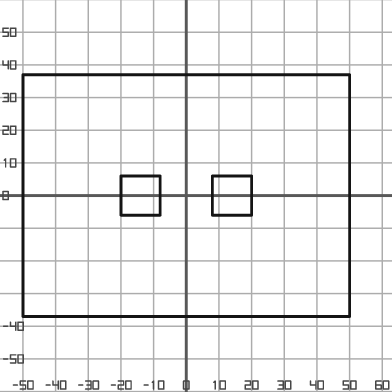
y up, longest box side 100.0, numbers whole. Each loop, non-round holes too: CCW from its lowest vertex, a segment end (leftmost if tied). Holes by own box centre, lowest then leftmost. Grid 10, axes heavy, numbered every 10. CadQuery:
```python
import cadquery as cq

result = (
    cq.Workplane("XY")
    .moveTo(-50.0, -37.0)
    .lineTo(50.0, -37.0)
    .lineTo(50.0, 37.0)
    .lineTo(-50.0, 37.0)
    .close()
    .moveTo(-20.0, -6.0)
    .lineTo(-8.0, -6.0)
    .lineTo(-8.0, 6.0)
    .lineTo(-20.0, 6.0)
    .close()
    .moveTo(8.0, -6.0)
    .lineTo(20.0, -6.0)
    .lineTo(20.0, 6.0)
    .lineTo(8.0, 6.0)
    .close()
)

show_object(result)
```